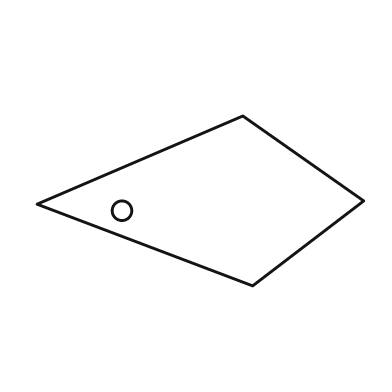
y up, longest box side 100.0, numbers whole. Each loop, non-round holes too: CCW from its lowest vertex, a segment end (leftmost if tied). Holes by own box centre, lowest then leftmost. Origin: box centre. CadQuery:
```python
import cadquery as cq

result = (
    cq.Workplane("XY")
    .moveTo(16.0, -26.0)
    .lineTo(50.0, 0.0)
    .lineTo(13.0, 26.0)
    .lineTo(-50.0, -1.0)
    .close()
    .moveTo(-24.0, -3.0)
    .circle(3.0)
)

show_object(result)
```